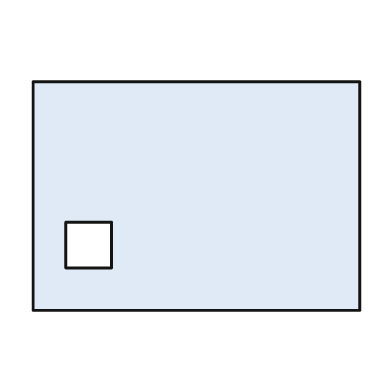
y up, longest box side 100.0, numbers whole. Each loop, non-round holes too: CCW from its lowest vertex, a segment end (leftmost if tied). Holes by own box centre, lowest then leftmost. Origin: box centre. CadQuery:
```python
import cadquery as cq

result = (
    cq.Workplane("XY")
    .moveTo(-50.0, -35.0)
    .lineTo(50.0, -35.0)
    .lineTo(50.0, 35.0)
    .lineTo(-50.0, 35.0)
    .close()
    .moveTo(-40.0, -22.0)
    .lineTo(-26.0, -22.0)
    .lineTo(-26.0, -8.0)
    .lineTo(-40.0, -8.0)
    .close()
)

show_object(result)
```